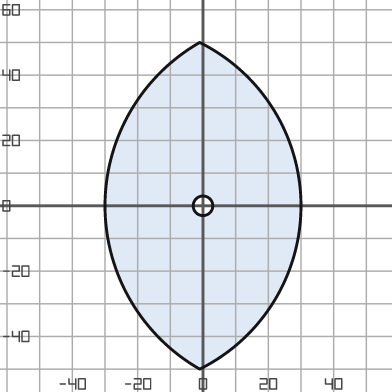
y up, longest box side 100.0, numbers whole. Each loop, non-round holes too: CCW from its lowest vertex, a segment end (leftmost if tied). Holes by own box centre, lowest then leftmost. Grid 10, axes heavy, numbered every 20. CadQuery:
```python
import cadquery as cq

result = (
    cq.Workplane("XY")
    .moveTo(-1.0, -50.0)
    .threePointArc((30.0, 0.0), (-1.0, 50.0))
    .threePointArc((-30.0, 0.0), (-1.0, -50.0))
    .close()
    .moveTo(0.0, 0.0)
    .circle(3.0)
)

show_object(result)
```